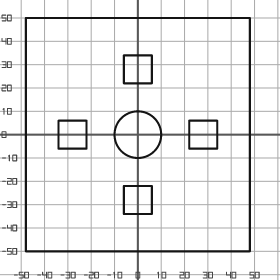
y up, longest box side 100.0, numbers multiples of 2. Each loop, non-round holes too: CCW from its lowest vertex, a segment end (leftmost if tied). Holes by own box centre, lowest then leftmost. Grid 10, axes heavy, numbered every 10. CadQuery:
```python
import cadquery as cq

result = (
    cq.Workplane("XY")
    .moveTo(-48.0, -50.0)
    .lineTo(48.0, -50.0)
    .lineTo(48.0, 50.0)
    .lineTo(-48.0, 50.0)
    .close()
    .moveTo(-6.0, -34.0)
    .lineTo(6.0, -34.0)
    .lineTo(6.0, -22.0)
    .lineTo(-6.0, -22.0)
    .close()
    .moveTo(-34.0, -6.0)
    .lineTo(-22.0, -6.0)
    .lineTo(-22.0, 6.0)
    .lineTo(-34.0, 6.0)
    .close()
    .moveTo(0.0, 0.0)
    .circle(10.0)
    .moveTo(22.0, -6.0)
    .lineTo(34.0, -6.0)
    .lineTo(34.0, 6.0)
    .lineTo(22.0, 6.0)
    .close()
    .moveTo(-6.0, 22.0)
    .lineTo(6.0, 22.0)
    .lineTo(6.0, 34.0)
    .lineTo(-6.0, 34.0)
    .close()
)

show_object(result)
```